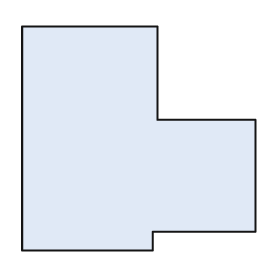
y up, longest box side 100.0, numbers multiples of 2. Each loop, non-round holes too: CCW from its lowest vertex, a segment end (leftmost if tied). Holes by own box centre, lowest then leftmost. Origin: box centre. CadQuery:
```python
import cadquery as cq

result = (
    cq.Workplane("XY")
    .moveTo(-50.0, -48.0)
    .lineTo(6.0, -48.0)
    .lineTo(6.0, -40.0)
    .lineTo(50.0, -40.0)
    .lineTo(50.0, 8.0)
    .lineTo(8.0, 8.0)
    .lineTo(8.0, 48.0)
    .lineTo(-50.0, 48.0)
    .close()
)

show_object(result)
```